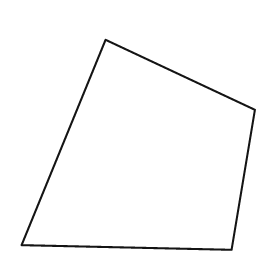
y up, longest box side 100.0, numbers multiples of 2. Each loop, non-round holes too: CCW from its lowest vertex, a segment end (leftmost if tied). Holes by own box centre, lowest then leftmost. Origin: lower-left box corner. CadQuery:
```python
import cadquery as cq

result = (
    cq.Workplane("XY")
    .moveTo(90.0, 0.0)
    .lineTo(100.0, 60.0)
    .lineTo(36.0, 90.0)
    .lineTo(0.0, 2.0)
    .close()
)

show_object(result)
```